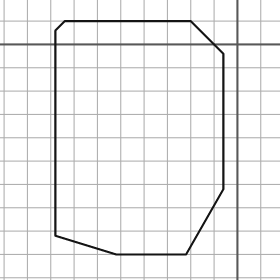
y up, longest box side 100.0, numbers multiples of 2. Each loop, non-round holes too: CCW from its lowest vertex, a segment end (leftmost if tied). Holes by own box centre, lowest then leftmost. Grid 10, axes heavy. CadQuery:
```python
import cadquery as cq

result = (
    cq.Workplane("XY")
    .moveTo(-52.0, -90.0)
    .lineTo(-22.0, -90.0)
    .lineTo(-6.0, -62.0)
    .lineTo(-6.0, -4.0)
    .lineTo(-20.0, 10.0)
    .lineTo(-74.0, 10.0)
    .lineTo(-78.0, 6.0)
    .lineTo(-78.0, -82.0)
    .close()
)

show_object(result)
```